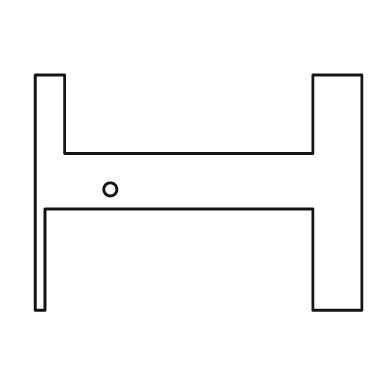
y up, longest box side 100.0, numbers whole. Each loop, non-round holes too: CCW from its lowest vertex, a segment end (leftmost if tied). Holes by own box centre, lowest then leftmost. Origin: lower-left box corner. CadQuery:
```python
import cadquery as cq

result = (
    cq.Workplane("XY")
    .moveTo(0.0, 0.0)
    .lineTo(3.0, 0.0)
    .lineTo(3.0, 31.0)
    .lineTo(85.0, 31.0)
    .lineTo(85.0, 0.0)
    .lineTo(100.0, 0.0)
    .lineTo(100.0, 72.0)
    .lineTo(85.0, 72.0)
    .lineTo(85.0, 48.0)
    .lineTo(9.0, 48.0)
    .lineTo(9.0, 72.0)
    .lineTo(0.0, 72.0)
    .close()
    .moveTo(23.0, 37.0)
    .circle(2.0)
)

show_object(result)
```